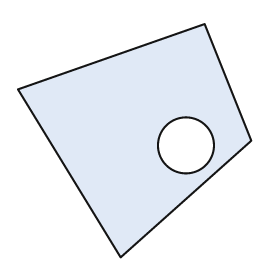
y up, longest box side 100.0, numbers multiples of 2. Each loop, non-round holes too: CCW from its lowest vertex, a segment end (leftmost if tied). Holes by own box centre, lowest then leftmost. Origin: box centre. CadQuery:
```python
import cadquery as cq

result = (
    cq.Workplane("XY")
    .moveTo(-6.0, -50.0)
    .lineTo(50.0, 0.0)
    .lineTo(30.0, 50.0)
    .lineTo(-50.0, 22.0)
    .close()
    .moveTo(22.0, -2.0)
    .circle(12.0)
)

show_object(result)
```